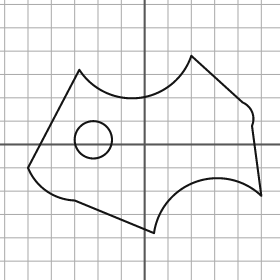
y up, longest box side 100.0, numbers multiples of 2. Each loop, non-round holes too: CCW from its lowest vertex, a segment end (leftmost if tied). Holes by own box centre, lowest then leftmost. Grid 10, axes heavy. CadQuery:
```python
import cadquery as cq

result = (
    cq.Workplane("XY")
    .moveTo(4.0, -38.0)
    .threePointArc((22.0, -16.0), (50.0, -22.0))
    .lineTo(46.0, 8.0)
    .threePointArc((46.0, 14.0), (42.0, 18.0))
    .lineTo(20.0, 38.0)
    .threePointArc((-2.0, 20.0), (-28.0, 32.0))
    .lineTo(-50.0, -10.0)
    .threePointArc((-42.0, -20.0), (-30.0, -24.0))
    .close()
    .moveTo(-22.0, 2.0)
    .circle(8.0)
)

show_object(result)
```